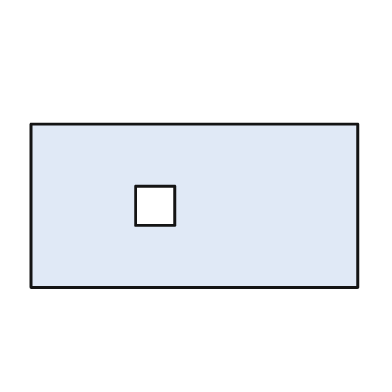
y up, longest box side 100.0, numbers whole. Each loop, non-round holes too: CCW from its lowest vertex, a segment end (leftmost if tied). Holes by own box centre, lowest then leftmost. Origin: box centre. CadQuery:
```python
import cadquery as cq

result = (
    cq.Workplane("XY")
    .moveTo(-50.0, -25.0)
    .lineTo(50.0, -25.0)
    .lineTo(50.0, 25.0)
    .lineTo(-50.0, 25.0)
    .close()
    .moveTo(-18.0, -6.0)
    .lineTo(-6.0, -6.0)
    .lineTo(-6.0, 6.0)
    .lineTo(-18.0, 6.0)
    .close()
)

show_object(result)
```